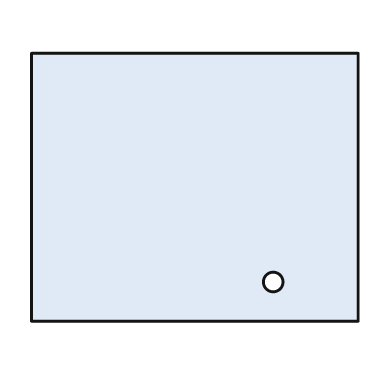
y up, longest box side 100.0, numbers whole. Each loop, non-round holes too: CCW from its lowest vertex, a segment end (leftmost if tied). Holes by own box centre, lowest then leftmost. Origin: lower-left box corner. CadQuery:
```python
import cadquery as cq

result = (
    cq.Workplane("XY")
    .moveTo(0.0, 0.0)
    .lineTo(100.0, 0.0)
    .lineTo(100.0, 82.0)
    .lineTo(0.0, 82.0)
    .close()
    .moveTo(74.0, 12.0)
    .circle(3.0)
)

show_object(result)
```